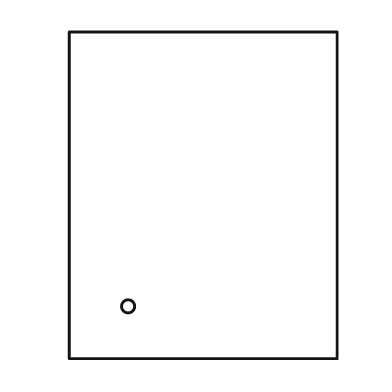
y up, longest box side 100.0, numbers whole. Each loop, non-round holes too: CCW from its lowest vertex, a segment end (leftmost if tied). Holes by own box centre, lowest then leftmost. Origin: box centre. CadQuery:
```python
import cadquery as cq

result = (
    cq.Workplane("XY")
    .moveTo(-41.0, -50.0)
    .lineTo(41.0, -50.0)
    .lineTo(41.0, 50.0)
    .lineTo(-41.0, 50.0)
    .close()
    .moveTo(-23.0, -34.0)
    .circle(2.0)
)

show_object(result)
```